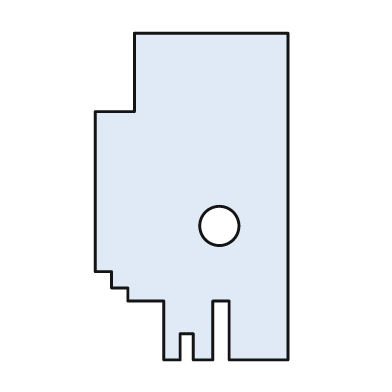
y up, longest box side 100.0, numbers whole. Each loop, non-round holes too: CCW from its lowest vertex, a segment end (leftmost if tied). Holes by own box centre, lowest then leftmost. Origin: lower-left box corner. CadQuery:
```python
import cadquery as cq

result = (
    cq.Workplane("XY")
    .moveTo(21.0, 0.0)
    .lineTo(26.0, 0.0)
    .lineTo(26.0, 8.0)
    .lineTo(30.0, 8.0)
    .lineTo(30.0, 0.0)
    .lineTo(36.0, 0.0)
    .lineTo(36.0, 18.0)
    .lineTo(41.0, 18.0)
    .lineTo(41.0, 0.0)
    .lineTo(59.0, 0.0)
    .lineTo(59.0, 100.0)
    .lineTo(12.0, 100.0)
    .lineTo(12.0, 76.0)
    .lineTo(0.0, 76.0)
    .lineTo(0.0, 27.0)
    .lineTo(5.0, 27.0)
    .lineTo(5.0, 22.0)
    .lineTo(10.0, 22.0)
    .lineTo(10.0, 18.0)
    .lineTo(21.0, 18.0)
    .close()
    .moveTo(38.0, 41.0)
    .circle(6.0)
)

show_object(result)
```